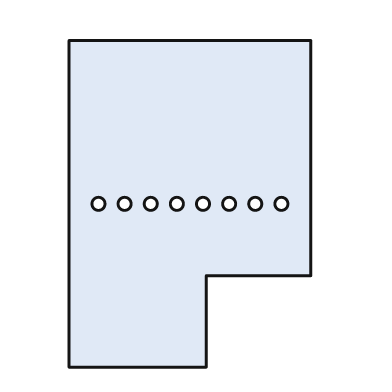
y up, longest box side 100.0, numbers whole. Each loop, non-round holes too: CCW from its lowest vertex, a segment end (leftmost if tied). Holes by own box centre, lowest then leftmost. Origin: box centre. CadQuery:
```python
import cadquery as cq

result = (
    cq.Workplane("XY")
    .moveTo(-37.0, -50.0)
    .lineTo(5.0, -50.0)
    .lineTo(5.0, -22.0)
    .lineTo(37.0, -22.0)
    .lineTo(37.0, 50.0)
    .lineTo(-37.0, 50.0)
    .close()
    .moveTo(-28.0, 0.0)
    .circle(2.0)
    .moveTo(-20.0, 0.0)
    .circle(2.0)
    .moveTo(-12.0, 0.0)
    .circle(2.0)
    .moveTo(-4.0, 0.0)
    .circle(2.0)
    .moveTo(4.0, 0.0)
    .circle(2.0)
    .moveTo(12.0, 0.0)
    .circle(2.0)
    .moveTo(20.0, 0.0)
    .circle(2.0)
    .moveTo(28.0, 0.0)
    .circle(2.0)
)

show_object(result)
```